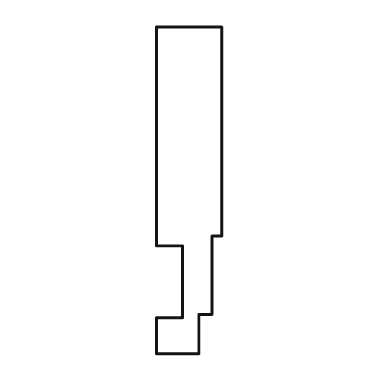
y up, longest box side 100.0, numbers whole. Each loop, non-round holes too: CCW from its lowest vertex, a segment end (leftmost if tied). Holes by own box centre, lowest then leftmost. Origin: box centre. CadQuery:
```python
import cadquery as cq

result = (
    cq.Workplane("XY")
    .moveTo(-10.0, -50.0)
    .lineTo(3.0, -50.0)
    .lineTo(3.0, -38.0)
    .lineTo(7.0, -38.0)
    .lineTo(7.0, -14.0)
    .lineTo(10.0, -14.0)
    .lineTo(10.0, 50.0)
    .lineTo(-10.0, 50.0)
    .lineTo(-10.0, -17.0)
    .lineTo(-2.0, -17.0)
    .lineTo(-2.0, -39.0)
    .lineTo(-10.0, -39.0)
    .close()
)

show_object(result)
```